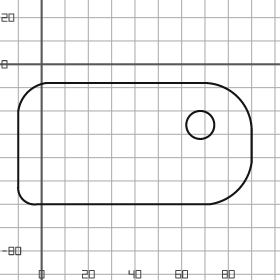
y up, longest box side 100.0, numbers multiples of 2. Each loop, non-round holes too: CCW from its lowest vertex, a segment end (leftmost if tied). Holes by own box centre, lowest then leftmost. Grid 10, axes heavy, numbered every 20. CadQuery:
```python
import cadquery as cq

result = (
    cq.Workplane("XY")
    .moveTo(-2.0, -60.0)
    .lineTo(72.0, -60.0)
    .threePointArc((84.0, -54.0), (90.0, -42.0))
    .lineTo(90.0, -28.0)
    .threePointArc((84.0, -14.0), (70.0, -8.0))
    .lineTo(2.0, -8.0)
    .threePointArc((-6.0, -12.0), (-10.0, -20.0))
    .lineTo(-10.0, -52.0)
    .threePointArc((-8.0, -58.0), (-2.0, -60.0))
    .close()
    .moveTo(68.0, -26.0)
    .circle(6.0)
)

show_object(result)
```